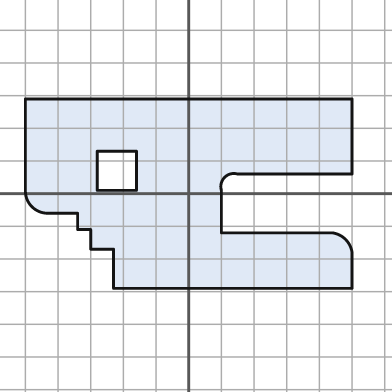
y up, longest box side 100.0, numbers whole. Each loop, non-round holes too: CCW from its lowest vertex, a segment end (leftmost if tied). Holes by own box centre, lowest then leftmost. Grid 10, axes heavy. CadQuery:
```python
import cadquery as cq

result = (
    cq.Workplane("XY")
    .moveTo(-23.0, -29.0)
    .lineTo(50.0, -29.0)
    .lineTo(50.0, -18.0)
    .threePointArc((48.0, -14.0), (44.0, -12.0))
    .lineTo(10.0, -12.0)
    .lineTo(10.0, 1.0)
    .threePointArc((11.0, 5.0), (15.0, 6.0))
    .lineTo(50.0, 6.0)
    .lineTo(50.0, 29.0)
    .lineTo(-50.0, 29.0)
    .lineTo(-50.0, 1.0)
    .threePointArc((-48.0, -4.0), (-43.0, -6.0))
    .lineTo(-34.0, -6.0)
    .lineTo(-34.0, -11.0)
    .lineTo(-30.0, -11.0)
    .lineTo(-30.0, -17.0)
    .lineTo(-23.0, -17.0)
    .close()
    .moveTo(-28.0, 1.0)
    .lineTo(-16.0, 1.0)
    .lineTo(-16.0, 13.0)
    .lineTo(-28.0, 13.0)
    .close()
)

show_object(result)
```